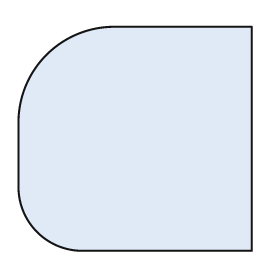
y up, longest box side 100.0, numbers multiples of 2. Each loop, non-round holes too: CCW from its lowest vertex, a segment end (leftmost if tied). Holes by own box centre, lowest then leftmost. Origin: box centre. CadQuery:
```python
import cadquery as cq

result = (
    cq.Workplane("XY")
    .moveTo(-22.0, -48.0)
    .lineTo(50.0, -48.0)
    .lineTo(50.0, 48.0)
    .lineTo(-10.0, 48.0)
    .threePointArc((-38.0, 36.0), (-50.0, 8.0))
    .lineTo(-50.0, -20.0)
    .threePointArc((-42.0, -40.0), (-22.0, -48.0))
    .close()
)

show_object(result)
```